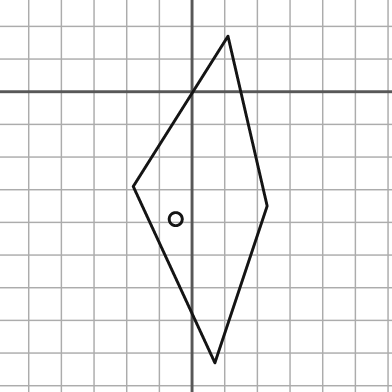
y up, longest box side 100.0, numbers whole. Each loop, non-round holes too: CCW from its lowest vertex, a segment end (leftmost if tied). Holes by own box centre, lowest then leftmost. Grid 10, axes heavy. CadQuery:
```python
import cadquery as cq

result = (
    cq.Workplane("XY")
    .moveTo(7.0, -83.0)
    .lineTo(23.0, -35.0)
    .lineTo(11.0, 17.0)
    .lineTo(-18.0, -29.0)
    .close()
    .moveTo(-5.0, -39.0)
    .circle(2.0)
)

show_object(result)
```